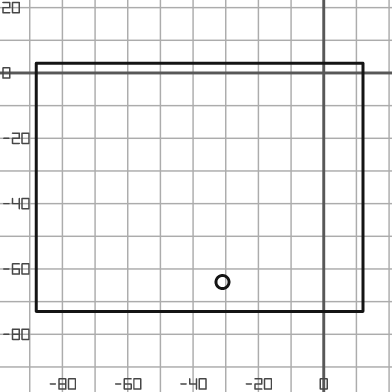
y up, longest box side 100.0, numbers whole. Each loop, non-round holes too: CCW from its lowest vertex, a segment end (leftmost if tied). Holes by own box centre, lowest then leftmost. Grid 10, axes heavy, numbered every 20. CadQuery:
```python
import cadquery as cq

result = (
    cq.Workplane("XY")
    .moveTo(-88.0, -73.0)
    .lineTo(12.0, -73.0)
    .lineTo(12.0, 3.0)
    .lineTo(-88.0, 3.0)
    .close()
    .moveTo(-31.0, -64.0)
    .circle(2.0)
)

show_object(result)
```